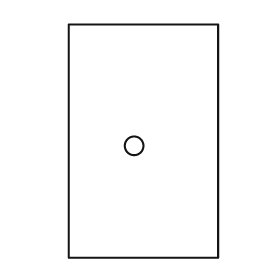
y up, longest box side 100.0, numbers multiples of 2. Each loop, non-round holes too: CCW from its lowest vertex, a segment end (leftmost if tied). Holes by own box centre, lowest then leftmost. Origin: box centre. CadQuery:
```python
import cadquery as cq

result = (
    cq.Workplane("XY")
    .moveTo(-32.0, -50.0)
    .lineTo(32.0, -50.0)
    .lineTo(32.0, 50.0)
    .lineTo(-32.0, 50.0)
    .close()
    .moveTo(-4.0, -2.0)
    .circle(4.0)
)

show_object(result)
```